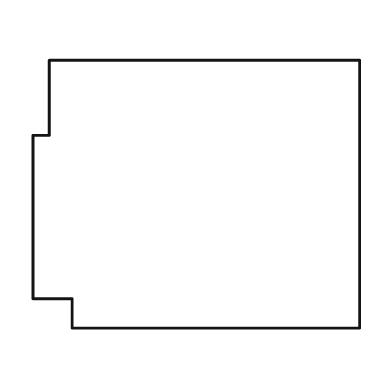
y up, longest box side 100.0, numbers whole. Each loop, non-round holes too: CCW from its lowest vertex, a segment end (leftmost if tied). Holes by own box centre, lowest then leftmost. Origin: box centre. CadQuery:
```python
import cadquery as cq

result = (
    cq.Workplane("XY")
    .moveTo(-38.0, -41.0)
    .lineTo(50.0, -41.0)
    .lineTo(50.0, 41.0)
    .lineTo(-45.0, 41.0)
    .lineTo(-45.0, 18.0)
    .lineTo(-50.0, 18.0)
    .lineTo(-50.0, -32.0)
    .lineTo(-38.0, -32.0)
    .close()
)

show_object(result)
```